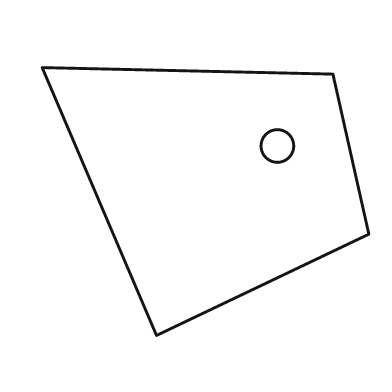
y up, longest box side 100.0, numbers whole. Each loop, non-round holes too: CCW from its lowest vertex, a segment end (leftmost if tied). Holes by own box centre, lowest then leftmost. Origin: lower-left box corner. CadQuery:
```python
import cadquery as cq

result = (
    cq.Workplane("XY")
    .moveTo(35.0, 0.0)
    .lineTo(100.0, 31.0)
    .lineTo(89.0, 80.0)
    .lineTo(0.0, 82.0)
    .close()
    .moveTo(72.0, 58.0)
    .circle(5.0)
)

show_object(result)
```